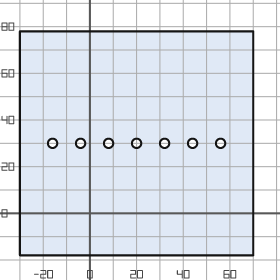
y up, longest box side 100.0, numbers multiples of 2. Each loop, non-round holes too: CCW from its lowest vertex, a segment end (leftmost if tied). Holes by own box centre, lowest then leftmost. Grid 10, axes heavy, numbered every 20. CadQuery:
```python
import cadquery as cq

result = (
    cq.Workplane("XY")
    .moveTo(-30.0, -18.0)
    .lineTo(70.0, -18.0)
    .lineTo(70.0, 78.0)
    .lineTo(-30.0, 78.0)
    .close()
    .moveTo(-16.0, 30.0)
    .circle(2.0)
    .moveTo(-4.0, 30.0)
    .circle(2.0)
    .moveTo(8.0, 30.0)
    .circle(2.0)
    .moveTo(20.0, 30.0)
    .circle(2.0)
    .moveTo(32.0, 30.0)
    .circle(2.0)
    .moveTo(44.0, 30.0)
    .circle(2.0)
    .moveTo(56.0, 30.0)
    .circle(2.0)
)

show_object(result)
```